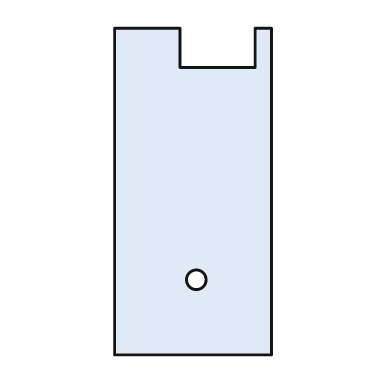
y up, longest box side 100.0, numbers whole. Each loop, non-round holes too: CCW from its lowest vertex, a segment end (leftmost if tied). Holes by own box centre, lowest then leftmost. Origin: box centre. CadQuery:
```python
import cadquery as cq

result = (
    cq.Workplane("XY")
    .moveTo(-24.0, -50.0)
    .lineTo(24.0, -50.0)
    .lineTo(24.0, 50.0)
    .lineTo(19.0, 50.0)
    .lineTo(19.0, 38.0)
    .lineTo(-4.0, 38.0)
    .lineTo(-4.0, 50.0)
    .lineTo(-24.0, 50.0)
    .close()
    .moveTo(1.0, -27.0)
    .circle(3.0)
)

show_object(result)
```